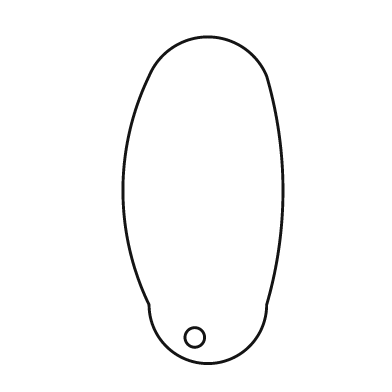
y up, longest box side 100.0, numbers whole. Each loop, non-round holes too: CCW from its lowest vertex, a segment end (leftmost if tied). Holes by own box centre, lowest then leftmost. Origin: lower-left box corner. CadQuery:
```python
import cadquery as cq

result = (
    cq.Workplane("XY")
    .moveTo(8.0, 18.0)
    .threePointArc((26.0, 0.0), (44.0, 18.0))
    .threePointArc((49.0, 53.0), (44.0, 88.0))
    .threePointArc((26.0, 100.0), (8.0, 88.0))
    .threePointArc((0.0, 53.0), (8.0, 18.0))
    .close()
    .moveTo(22.0, 8.0)
    .circle(3.0)
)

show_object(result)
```